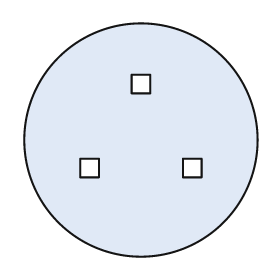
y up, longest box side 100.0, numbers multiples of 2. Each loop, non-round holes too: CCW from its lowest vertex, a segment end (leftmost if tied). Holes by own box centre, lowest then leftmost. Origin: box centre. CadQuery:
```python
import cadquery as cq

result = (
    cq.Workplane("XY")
    .moveTo(0.0, 0.0)
    .circle(50.0)
    .moveTo(-26.0, -16.0)
    .lineTo(-18.0, -16.0)
    .lineTo(-18.0, -8.0)
    .lineTo(-26.0, -8.0)
    .close()
    .moveTo(18.0, -16.0)
    .lineTo(26.0, -16.0)
    .lineTo(26.0, -8.0)
    .lineTo(18.0, -8.0)
    .close()
    .moveTo(-4.0, 20.0)
    .lineTo(4.0, 20.0)
    .lineTo(4.0, 28.0)
    .lineTo(-4.0, 28.0)
    .close()
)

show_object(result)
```